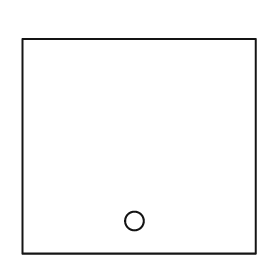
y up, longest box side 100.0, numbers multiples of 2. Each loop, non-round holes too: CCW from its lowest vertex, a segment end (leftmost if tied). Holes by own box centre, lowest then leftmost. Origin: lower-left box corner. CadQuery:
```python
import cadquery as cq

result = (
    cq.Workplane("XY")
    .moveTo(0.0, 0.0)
    .lineTo(100.0, 0.0)
    .lineTo(100.0, 92.0)
    .lineTo(0.0, 92.0)
    .close()
    .moveTo(48.0, 14.0)
    .circle(4.0)
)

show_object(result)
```